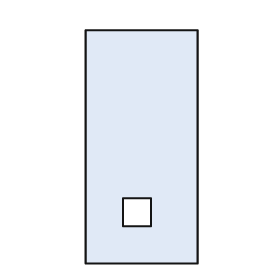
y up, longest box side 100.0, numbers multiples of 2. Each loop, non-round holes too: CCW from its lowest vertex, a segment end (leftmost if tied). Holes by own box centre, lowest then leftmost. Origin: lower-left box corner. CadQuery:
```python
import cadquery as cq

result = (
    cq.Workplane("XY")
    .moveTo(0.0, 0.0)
    .lineTo(48.0, 0.0)
    .lineTo(48.0, 100.0)
    .lineTo(0.0, 100.0)
    .close()
    .moveTo(16.0, 16.0)
    .lineTo(28.0, 16.0)
    .lineTo(28.0, 28.0)
    .lineTo(16.0, 28.0)
    .close()
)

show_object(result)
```